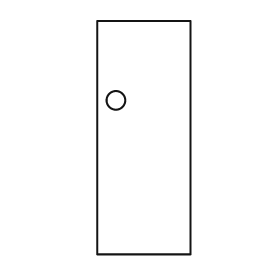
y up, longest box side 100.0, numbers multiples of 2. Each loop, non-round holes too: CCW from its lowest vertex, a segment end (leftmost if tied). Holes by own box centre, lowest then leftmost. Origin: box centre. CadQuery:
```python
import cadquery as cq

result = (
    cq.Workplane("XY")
    .moveTo(-20.0, -50.0)
    .lineTo(20.0, -50.0)
    .lineTo(20.0, 50.0)
    .lineTo(-20.0, 50.0)
    .close()
    .moveTo(-12.0, 16.0)
    .circle(4.0)
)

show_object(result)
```